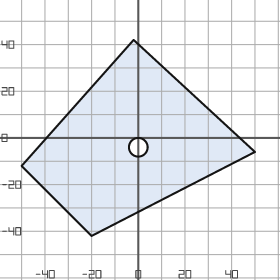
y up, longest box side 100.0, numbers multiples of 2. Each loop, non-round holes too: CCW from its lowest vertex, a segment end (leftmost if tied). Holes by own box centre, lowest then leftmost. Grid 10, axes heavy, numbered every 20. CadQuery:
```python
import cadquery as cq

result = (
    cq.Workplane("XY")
    .moveTo(-20.0, -42.0)
    .lineTo(50.0, -6.0)
    .lineTo(-2.0, 42.0)
    .lineTo(-50.0, -12.0)
    .close()
    .moveTo(0.0, -4.0)
    .circle(4.0)
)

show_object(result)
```